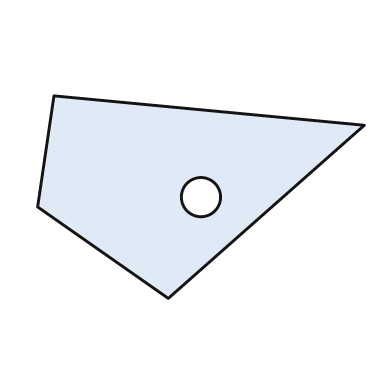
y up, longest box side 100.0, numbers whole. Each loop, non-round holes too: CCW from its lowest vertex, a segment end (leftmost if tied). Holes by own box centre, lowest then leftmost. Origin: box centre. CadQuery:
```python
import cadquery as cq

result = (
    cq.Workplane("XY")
    .moveTo(-10.0, -31.0)
    .lineTo(50.0, 22.0)
    .lineTo(-45.0, 31.0)
    .lineTo(-50.0, -3.0)
    .close()
    .moveTo(0.0, 0.0)
    .circle(6.0)
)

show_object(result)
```